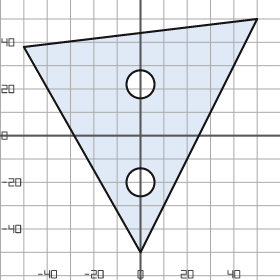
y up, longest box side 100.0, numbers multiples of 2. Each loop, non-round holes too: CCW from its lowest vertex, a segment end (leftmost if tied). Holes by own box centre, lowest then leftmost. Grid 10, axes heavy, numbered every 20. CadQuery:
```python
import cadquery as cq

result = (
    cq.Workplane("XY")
    .moveTo(0.0, -50.0)
    .lineTo(50.0, 50.0)
    .lineTo(-50.0, 38.0)
    .close()
    .moveTo(0.0, -20.0)
    .circle(6.0)
    .moveTo(0.0, 22.0)
    .circle(6.0)
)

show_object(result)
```